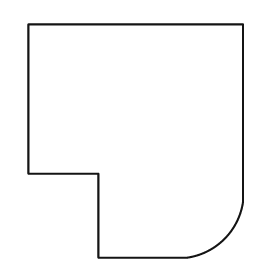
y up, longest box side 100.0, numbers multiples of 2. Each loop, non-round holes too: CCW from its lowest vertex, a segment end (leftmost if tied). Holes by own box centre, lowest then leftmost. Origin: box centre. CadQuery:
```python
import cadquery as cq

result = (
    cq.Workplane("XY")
    .moveTo(-16.0, -50.0)
    .lineTo(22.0, -50.0)
    .threePointArc((38.0, -42.0), (46.0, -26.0))
    .lineTo(46.0, 50.0)
    .lineTo(-46.0, 50.0)
    .lineTo(-46.0, -14.0)
    .lineTo(-16.0, -14.0)
    .close()
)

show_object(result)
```